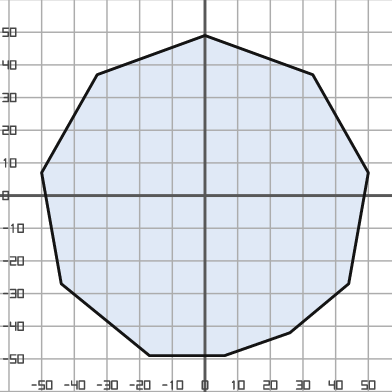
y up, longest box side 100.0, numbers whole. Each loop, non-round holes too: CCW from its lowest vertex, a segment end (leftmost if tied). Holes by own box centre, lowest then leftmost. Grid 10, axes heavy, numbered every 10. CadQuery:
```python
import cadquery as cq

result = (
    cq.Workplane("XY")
    .moveTo(-17.0, -49.0)
    .lineTo(6.0, -49.0)
    .lineTo(26.0, -42.0)
    .lineTo(44.0, -27.0)
    .lineTo(50.0, 7.0)
    .lineTo(33.0, 37.0)
    .lineTo(0.0, 49.0)
    .lineTo(-33.0, 37.0)
    .lineTo(-50.0, 7.0)
    .lineTo(-44.0, -27.0)
    .close()
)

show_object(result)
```